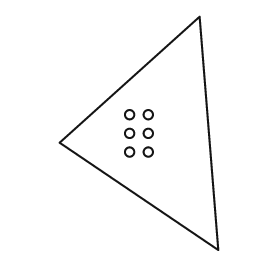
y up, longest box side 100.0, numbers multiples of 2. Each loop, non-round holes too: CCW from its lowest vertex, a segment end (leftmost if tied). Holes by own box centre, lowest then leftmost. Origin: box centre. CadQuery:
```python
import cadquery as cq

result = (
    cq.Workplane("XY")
    .moveTo(34.0, -50.0)
    .lineTo(26.0, 50.0)
    .lineTo(-34.0, -4.0)
    .close()
    .moveTo(-4.0, -8.0)
    .circle(2.0)
    .moveTo(4.0, -8.0)
    .circle(2.0)
    .moveTo(-4.0, 0.0)
    .circle(2.0)
    .moveTo(4.0, 0.0)
    .circle(2.0)
    .moveTo(-4.0, 8.0)
    .circle(2.0)
    .moveTo(4.0, 8.0)
    .circle(2.0)
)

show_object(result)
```